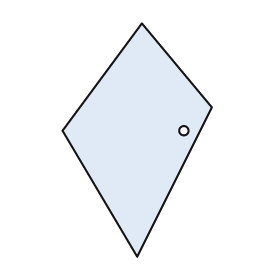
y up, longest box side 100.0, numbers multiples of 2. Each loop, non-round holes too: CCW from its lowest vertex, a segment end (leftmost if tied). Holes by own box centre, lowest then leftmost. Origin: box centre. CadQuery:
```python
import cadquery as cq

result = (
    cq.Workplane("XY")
    .moveTo(0.0, -50.0)
    .lineTo(32.0, 14.0)
    .lineTo(2.0, 50.0)
    .lineTo(-32.0, 4.0)
    .close()
    .moveTo(20.0, 4.0)
    .circle(2.0)
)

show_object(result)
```